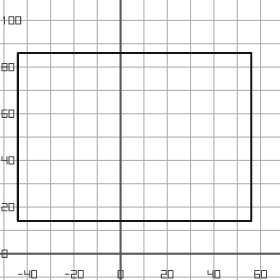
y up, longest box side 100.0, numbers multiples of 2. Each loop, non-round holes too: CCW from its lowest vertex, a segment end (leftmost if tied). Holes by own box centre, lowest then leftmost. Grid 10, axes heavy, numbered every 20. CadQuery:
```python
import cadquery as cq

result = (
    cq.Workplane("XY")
    .moveTo(-44.0, 14.0)
    .lineTo(56.0, 14.0)
    .lineTo(56.0, 86.0)
    .lineTo(-44.0, 86.0)
    .close()
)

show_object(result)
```